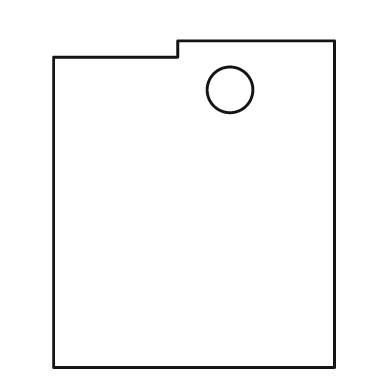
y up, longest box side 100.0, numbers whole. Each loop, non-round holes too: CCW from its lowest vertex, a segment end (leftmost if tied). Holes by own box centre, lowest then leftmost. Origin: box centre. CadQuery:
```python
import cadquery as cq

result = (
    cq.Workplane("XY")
    .moveTo(-43.0, -50.0)
    .lineTo(43.0, -50.0)
    .lineTo(43.0, 50.0)
    .lineTo(-5.0, 50.0)
    .lineTo(-5.0, 45.0)
    .lineTo(-43.0, 45.0)
    .close()
    .moveTo(11.0, 35.0)
    .circle(7.0)
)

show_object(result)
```